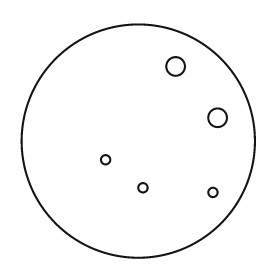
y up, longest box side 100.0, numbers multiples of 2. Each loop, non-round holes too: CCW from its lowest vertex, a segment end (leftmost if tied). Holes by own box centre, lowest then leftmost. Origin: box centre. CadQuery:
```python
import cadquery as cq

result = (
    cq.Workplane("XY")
    .moveTo(0.0, 0.0)
    .circle(50.0)
    .moveTo(32.0, -22.0)
    .circle(2.0)
    .moveTo(2.0, -20.0)
    .circle(2.0)
    .moveTo(-14.0, -8.0)
    .circle(2.0)
    .moveTo(34.0, 10.0)
    .circle(4.0)
    .moveTo(16.0, 32.0)
    .circle(4.0)
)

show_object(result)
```